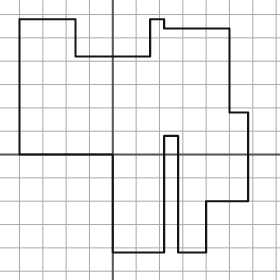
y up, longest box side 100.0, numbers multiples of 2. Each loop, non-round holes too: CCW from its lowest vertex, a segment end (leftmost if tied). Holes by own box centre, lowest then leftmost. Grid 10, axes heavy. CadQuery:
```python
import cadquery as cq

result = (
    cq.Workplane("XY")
    .moveTo(0.0, -42.0)
    .lineTo(22.0, -42.0)
    .lineTo(22.0, 8.0)
    .lineTo(28.0, 8.0)
    .lineTo(28.0, -42.0)
    .lineTo(40.0, -42.0)
    .lineTo(40.0, -20.0)
    .lineTo(58.0, -20.0)
    .lineTo(58.0, 18.0)
    .lineTo(50.0, 18.0)
    .lineTo(50.0, 54.0)
    .lineTo(22.0, 54.0)
    .lineTo(22.0, 58.0)
    .lineTo(16.0, 58.0)
    .lineTo(16.0, 42.0)
    .lineTo(-16.0, 42.0)
    .lineTo(-16.0, 58.0)
    .lineTo(-40.0, 58.0)
    .lineTo(-40.0, 0.0)
    .lineTo(0.0, 0.0)
    .close()
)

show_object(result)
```